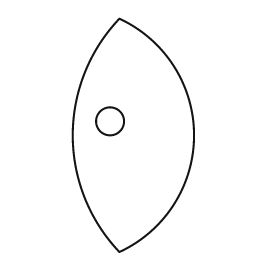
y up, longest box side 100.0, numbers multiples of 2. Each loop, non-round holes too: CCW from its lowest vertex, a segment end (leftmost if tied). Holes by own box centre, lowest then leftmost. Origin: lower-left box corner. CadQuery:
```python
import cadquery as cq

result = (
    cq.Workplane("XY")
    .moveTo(20.0, 0.0)
    .threePointArc((52.0, 50.0), (20.0, 100.0))
    .threePointArc((0.0, 50.0), (20.0, 0.0))
    .close()
    .moveTo(16.0, 56.0)
    .circle(6.0)
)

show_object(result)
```